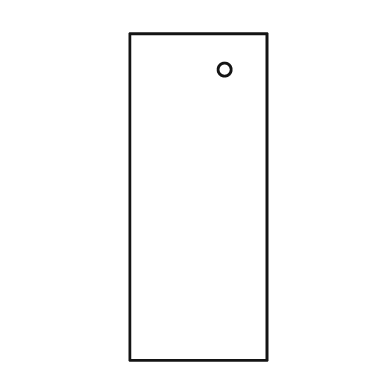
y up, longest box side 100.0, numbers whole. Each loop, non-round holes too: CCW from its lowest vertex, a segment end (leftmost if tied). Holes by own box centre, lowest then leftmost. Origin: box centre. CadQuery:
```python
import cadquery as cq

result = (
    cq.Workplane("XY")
    .moveTo(-21.0, -50.0)
    .lineTo(21.0, -50.0)
    .lineTo(21.0, 50.0)
    .lineTo(-21.0, 50.0)
    .close()
    .moveTo(8.0, 39.0)
    .circle(2.0)
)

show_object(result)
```